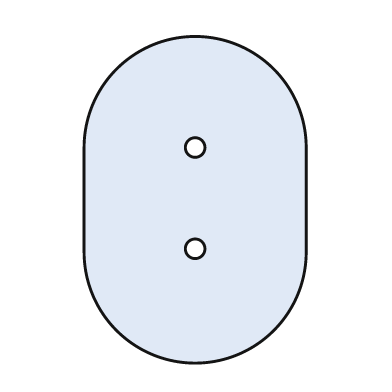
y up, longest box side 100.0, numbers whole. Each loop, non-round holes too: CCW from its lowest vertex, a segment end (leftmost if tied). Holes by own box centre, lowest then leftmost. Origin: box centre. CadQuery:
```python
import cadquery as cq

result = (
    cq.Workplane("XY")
    .moveTo(-34.0, -16.0)
    .threePointArc((0.0, -50.0), (34.0, -16.0))
    .lineTo(34.0, 16.0)
    .threePointArc((0.0, 50.0), (-34.0, 16.0))
    .close()
    .moveTo(0.0, -15.0)
    .circle(3.0)
    .moveTo(0.0, 16.0)
    .circle(3.0)
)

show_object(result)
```